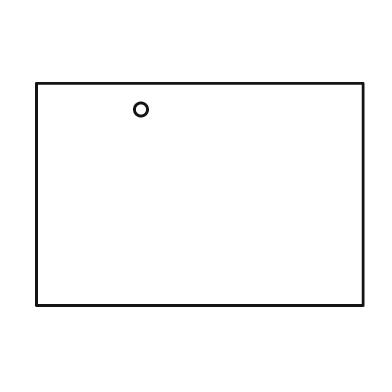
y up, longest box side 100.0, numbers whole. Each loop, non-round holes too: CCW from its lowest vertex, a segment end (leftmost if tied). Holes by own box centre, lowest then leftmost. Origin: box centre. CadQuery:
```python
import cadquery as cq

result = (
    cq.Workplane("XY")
    .moveTo(-50.0, -34.0)
    .lineTo(50.0, -34.0)
    .lineTo(50.0, 34.0)
    .lineTo(-50.0, 34.0)
    .close()
    .moveTo(-18.0, 26.0)
    .circle(2.0)
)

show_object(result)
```